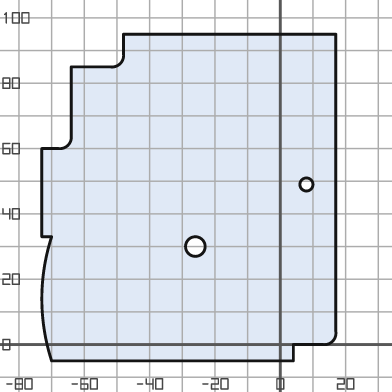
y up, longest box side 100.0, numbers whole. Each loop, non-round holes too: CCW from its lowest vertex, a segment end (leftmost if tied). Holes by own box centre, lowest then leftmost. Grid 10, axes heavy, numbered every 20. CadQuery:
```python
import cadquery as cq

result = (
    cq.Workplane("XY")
    .moveTo(-70.0, -5.0)
    .lineTo(4.0, -5.0)
    .lineTo(4.0, 0.0)
    .lineTo(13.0, 0.0)
    .threePointArc((16.0, 1.0), (17.0, 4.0))
    .lineTo(17.0, 95.0)
    .lineTo(-48.0, 95.0)
    .lineTo(-48.0, 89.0)
    .threePointArc((-49.0, 86.0), (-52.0, 85.0))
    .lineTo(-64.0, 85.0)
    .lineTo(-64.0, 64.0)
    .threePointArc((-65.0, 61.0), (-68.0, 60.0))
    .lineTo(-73.0, 60.0)
    .lineTo(-73.0, 33.0)
    .lineTo(-70.0, 33.0)
    .threePointArc((-73.0, 14.0), (-70.0, -5.0))
    .close()
    .moveTo(-26.0, 30.0)
    .circle(3.0)
    .moveTo(8.0, 49.0)
    .circle(2.0)
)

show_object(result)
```